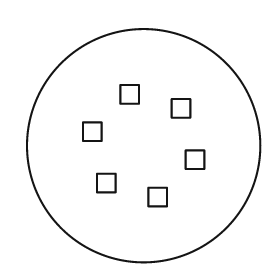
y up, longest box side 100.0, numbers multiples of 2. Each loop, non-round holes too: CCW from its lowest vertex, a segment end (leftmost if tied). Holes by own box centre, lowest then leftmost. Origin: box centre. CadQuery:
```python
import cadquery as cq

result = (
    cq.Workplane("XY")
    .moveTo(0.0, 0.0)
    .circle(50.0)
    .moveTo(2.0, -26.0)
    .lineTo(10.0, -26.0)
    .lineTo(10.0, -18.0)
    .lineTo(2.0, -18.0)
    .close()
    .moveTo(-20.0, -20.0)
    .lineTo(-12.0, -20.0)
    .lineTo(-12.0, -12.0)
    .lineTo(-20.0, -12.0)
    .close()
    .moveTo(18.0, -10.0)
    .lineTo(26.0, -10.0)
    .lineTo(26.0, -2.0)
    .lineTo(18.0, -2.0)
    .close()
    .moveTo(-26.0, 2.0)
    .lineTo(-18.0, 2.0)
    .lineTo(-18.0, 10.0)
    .lineTo(-26.0, 10.0)
    .close()
    .moveTo(12.0, 12.0)
    .lineTo(20.0, 12.0)
    .lineTo(20.0, 20.0)
    .lineTo(12.0, 20.0)
    .close()
    .moveTo(-10.0, 18.0)
    .lineTo(-2.0, 18.0)
    .lineTo(-2.0, 26.0)
    .lineTo(-10.0, 26.0)
    .close()
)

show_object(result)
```